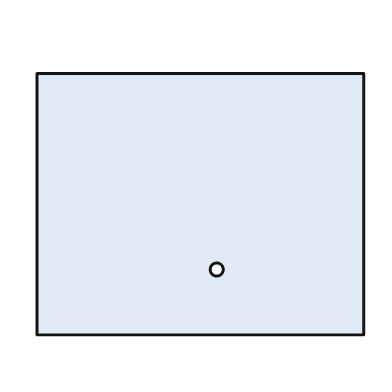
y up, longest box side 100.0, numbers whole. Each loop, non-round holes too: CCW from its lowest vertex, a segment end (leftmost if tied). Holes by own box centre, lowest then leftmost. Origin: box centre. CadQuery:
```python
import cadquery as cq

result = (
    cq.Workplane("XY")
    .moveTo(-50.0, -40.0)
    .lineTo(50.0, -40.0)
    .lineTo(50.0, 40.0)
    .lineTo(-50.0, 40.0)
    .close()
    .moveTo(5.0, -20.0)
    .circle(2.0)
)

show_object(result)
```